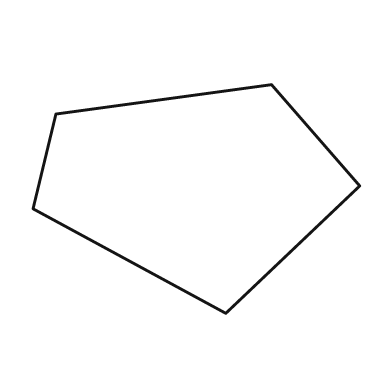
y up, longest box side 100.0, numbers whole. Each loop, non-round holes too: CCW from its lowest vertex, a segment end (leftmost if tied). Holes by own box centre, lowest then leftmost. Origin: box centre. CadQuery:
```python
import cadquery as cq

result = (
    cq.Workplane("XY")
    .moveTo(9.0, -35.0)
    .lineTo(50.0, 4.0)
    .lineTo(23.0, 35.0)
    .lineTo(-43.0, 26.0)
    .lineTo(-50.0, -3.0)
    .close()
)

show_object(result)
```